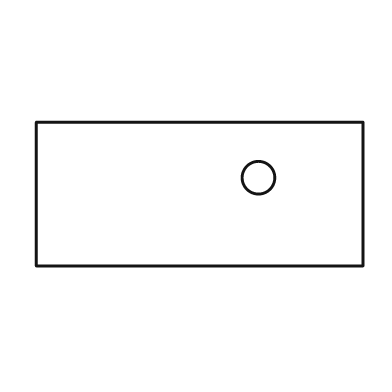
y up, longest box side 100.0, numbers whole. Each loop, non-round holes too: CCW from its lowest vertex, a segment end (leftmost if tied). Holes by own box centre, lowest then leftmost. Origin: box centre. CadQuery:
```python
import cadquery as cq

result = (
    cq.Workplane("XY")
    .moveTo(-50.0, -22.0)
    .lineTo(50.0, -22.0)
    .lineTo(50.0, 22.0)
    .lineTo(-50.0, 22.0)
    .close()
    .moveTo(18.0, 5.0)
    .circle(5.0)
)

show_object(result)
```